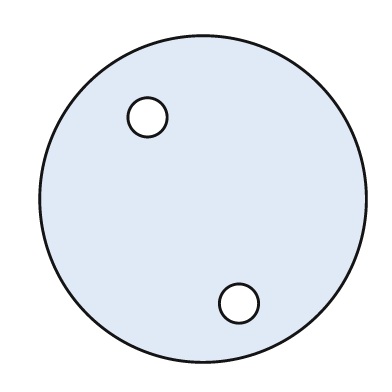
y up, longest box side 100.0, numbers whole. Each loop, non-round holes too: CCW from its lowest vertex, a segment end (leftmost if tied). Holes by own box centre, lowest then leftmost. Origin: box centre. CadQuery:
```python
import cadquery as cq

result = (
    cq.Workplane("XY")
    .moveTo(0.0, 0.0)
    .circle(50.0)
    .moveTo(11.0, -32.0)
    .circle(6.0)
    .moveTo(-17.0, 25.0)
    .circle(6.0)
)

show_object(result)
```